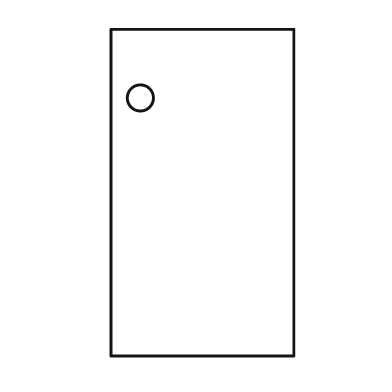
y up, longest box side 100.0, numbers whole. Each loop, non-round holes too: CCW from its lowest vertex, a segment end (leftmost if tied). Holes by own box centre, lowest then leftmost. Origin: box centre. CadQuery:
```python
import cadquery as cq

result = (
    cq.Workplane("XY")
    .moveTo(-28.0, -50.0)
    .lineTo(28.0, -50.0)
    .lineTo(28.0, 50.0)
    .lineTo(-28.0, 50.0)
    .close()
    .moveTo(-19.0, 29.0)
    .circle(4.0)
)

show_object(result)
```